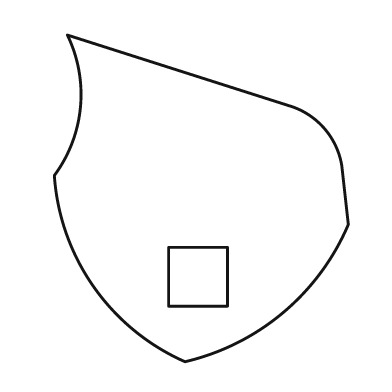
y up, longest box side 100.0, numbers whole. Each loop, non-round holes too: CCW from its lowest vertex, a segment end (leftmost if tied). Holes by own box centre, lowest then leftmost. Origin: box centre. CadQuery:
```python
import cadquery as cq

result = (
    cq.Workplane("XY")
    .moveTo(-5.0, -50.0)
    .threePointArc((25.0, -35.0), (45.0, -8.0))
    .lineTo(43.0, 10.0)
    .threePointArc((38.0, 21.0), (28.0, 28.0))
    .lineTo(-41.0, 50.0)
    .threePointArc((-37.0, 28.0), (-45.0, 7.0))
    .threePointArc((-33.0, -27.0), (-5.0, -50.0))
    .close()
    .moveTo(-10.0, -33.0)
    .lineTo(8.0, -33.0)
    .lineTo(8.0, -15.0)
    .lineTo(-10.0, -15.0)
    .close()
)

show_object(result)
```